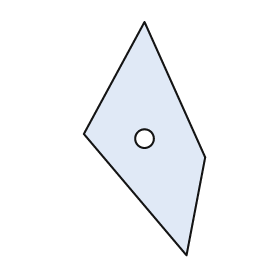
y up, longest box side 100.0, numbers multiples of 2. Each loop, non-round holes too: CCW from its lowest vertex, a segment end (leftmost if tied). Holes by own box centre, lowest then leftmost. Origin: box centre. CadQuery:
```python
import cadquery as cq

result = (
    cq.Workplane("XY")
    .moveTo(18.0, -50.0)
    .lineTo(26.0, -8.0)
    .lineTo(0.0, 50.0)
    .lineTo(-26.0, 2.0)
    .close()
    .moveTo(0.0, 0.0)
    .circle(4.0)
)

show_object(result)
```